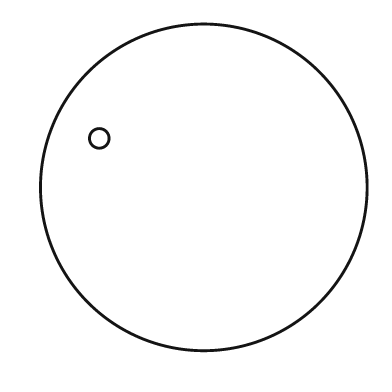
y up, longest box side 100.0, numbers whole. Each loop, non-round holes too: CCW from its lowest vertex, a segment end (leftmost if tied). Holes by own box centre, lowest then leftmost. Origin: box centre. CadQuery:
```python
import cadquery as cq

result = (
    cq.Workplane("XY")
    .moveTo(0.0, 0.0)
    .circle(50.0)
    .moveTo(-32.0, 15.0)
    .circle(3.0)
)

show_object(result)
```